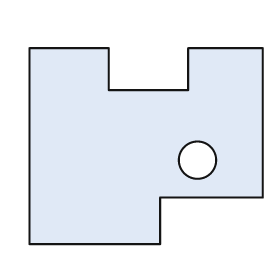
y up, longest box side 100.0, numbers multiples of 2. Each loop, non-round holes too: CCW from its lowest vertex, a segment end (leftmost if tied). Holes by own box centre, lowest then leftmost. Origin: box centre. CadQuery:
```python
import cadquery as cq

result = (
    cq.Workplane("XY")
    .moveTo(-50.0, -42.0)
    .lineTo(6.0, -42.0)
    .lineTo(6.0, -22.0)
    .lineTo(50.0, -22.0)
    .lineTo(50.0, 42.0)
    .lineTo(18.0, 42.0)
    .lineTo(18.0, 24.0)
    .lineTo(-16.0, 24.0)
    .lineTo(-16.0, 42.0)
    .lineTo(-50.0, 42.0)
    .close()
    .moveTo(22.0, -6.0)
    .circle(8.0)
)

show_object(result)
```